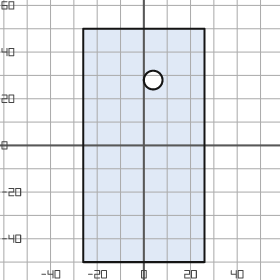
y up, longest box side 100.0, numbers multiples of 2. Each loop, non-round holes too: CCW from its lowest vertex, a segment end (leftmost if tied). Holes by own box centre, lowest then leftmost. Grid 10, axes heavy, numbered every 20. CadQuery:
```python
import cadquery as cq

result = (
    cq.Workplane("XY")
    .moveTo(-26.0, -50.0)
    .lineTo(26.0, -50.0)
    .lineTo(26.0, 50.0)
    .lineTo(-26.0, 50.0)
    .close()
    .moveTo(4.0, 28.0)
    .circle(4.0)
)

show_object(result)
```